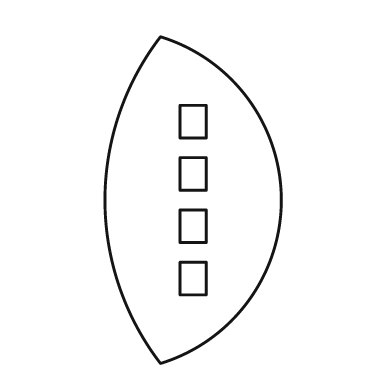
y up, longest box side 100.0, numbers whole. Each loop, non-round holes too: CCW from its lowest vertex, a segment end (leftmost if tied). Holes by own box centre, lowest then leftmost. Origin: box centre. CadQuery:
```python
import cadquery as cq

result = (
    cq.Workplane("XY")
    .moveTo(-10.0, -50.0)
    .threePointArc((27.0, 0.0), (-10.0, 50.0))
    .threePointArc((-27.0, 0.0), (-10.0, -50.0))
    .close()
    .moveTo(-4.0, -29.0)
    .lineTo(4.0, -29.0)
    .lineTo(4.0, -19.0)
    .lineTo(-4.0, -19.0)
    .close()
    .moveTo(-4.0, -13.0)
    .lineTo(4.0, -13.0)
    .lineTo(4.0, -3.0)
    .lineTo(-4.0, -3.0)
    .close()
    .moveTo(-4.0, 3.0)
    .lineTo(4.0, 3.0)
    .lineTo(4.0, 13.0)
    .lineTo(-4.0, 13.0)
    .close()
    .moveTo(-4.0, 19.0)
    .lineTo(4.0, 19.0)
    .lineTo(4.0, 29.0)
    .lineTo(-4.0, 29.0)
    .close()
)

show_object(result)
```